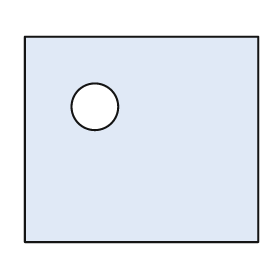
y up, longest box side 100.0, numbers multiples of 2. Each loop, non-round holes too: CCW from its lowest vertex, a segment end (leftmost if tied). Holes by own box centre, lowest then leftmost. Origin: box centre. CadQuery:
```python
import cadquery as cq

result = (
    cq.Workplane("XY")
    .moveTo(-50.0, -44.0)
    .lineTo(50.0, -44.0)
    .lineTo(50.0, 44.0)
    .lineTo(-50.0, 44.0)
    .close()
    .moveTo(-20.0, 14.0)
    .circle(10.0)
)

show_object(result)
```